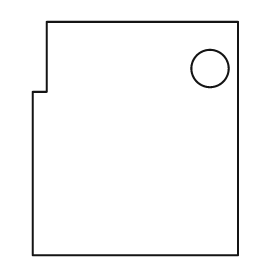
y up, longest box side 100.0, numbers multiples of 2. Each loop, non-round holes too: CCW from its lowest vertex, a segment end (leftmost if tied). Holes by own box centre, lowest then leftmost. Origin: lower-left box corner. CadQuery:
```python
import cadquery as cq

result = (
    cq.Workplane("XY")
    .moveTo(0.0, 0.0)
    .lineTo(88.0, 0.0)
    .lineTo(88.0, 100.0)
    .lineTo(6.0, 100.0)
    .lineTo(6.0, 70.0)
    .lineTo(0.0, 70.0)
    .close()
    .moveTo(76.0, 80.0)
    .circle(8.0)
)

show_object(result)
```